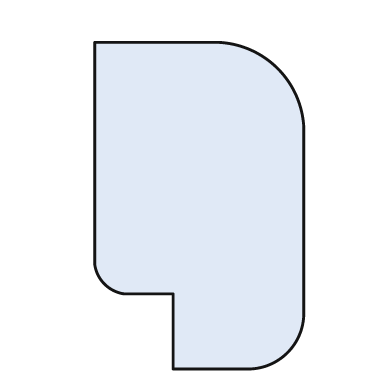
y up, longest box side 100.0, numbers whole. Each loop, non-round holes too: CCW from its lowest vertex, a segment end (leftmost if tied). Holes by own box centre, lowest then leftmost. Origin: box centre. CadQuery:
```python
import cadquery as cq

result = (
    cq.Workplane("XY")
    .moveTo(-8.0, -50.0)
    .lineTo(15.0, -50.0)
    .threePointArc((27.0, -45.0), (32.0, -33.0))
    .lineTo(32.0, 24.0)
    .threePointArc((24.0, 42.0), (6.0, 50.0))
    .lineTo(-32.0, 50.0)
    .lineTo(-32.0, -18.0)
    .threePointArc((-29.0, -24.0), (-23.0, -27.0))
    .lineTo(-8.0, -27.0)
    .close()
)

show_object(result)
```